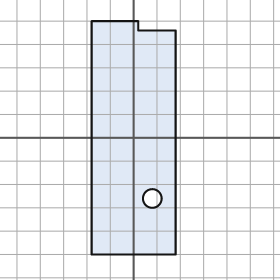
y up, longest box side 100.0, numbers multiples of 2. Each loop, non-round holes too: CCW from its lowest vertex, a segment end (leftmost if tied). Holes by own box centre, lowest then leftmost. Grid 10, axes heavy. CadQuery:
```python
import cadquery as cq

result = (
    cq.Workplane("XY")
    .moveTo(-18.0, -50.0)
    .lineTo(18.0, -50.0)
    .lineTo(18.0, 46.0)
    .lineTo(2.0, 46.0)
    .lineTo(2.0, 50.0)
    .lineTo(-18.0, 50.0)
    .close()
    .moveTo(8.0, -26.0)
    .circle(4.0)
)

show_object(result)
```